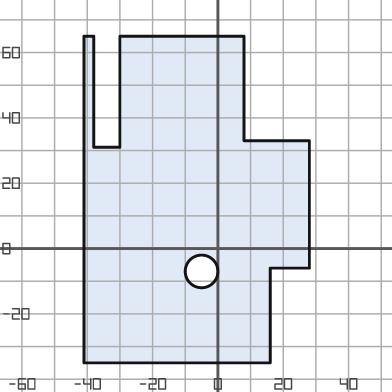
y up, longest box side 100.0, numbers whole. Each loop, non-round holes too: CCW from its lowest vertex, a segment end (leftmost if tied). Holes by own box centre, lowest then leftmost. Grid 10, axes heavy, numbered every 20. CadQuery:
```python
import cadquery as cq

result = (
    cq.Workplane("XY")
    .moveTo(-41.0, -35.0)
    .lineTo(16.0, -35.0)
    .lineTo(16.0, -6.0)
    .lineTo(28.0, -6.0)
    .lineTo(28.0, 33.0)
    .lineTo(8.0, 33.0)
    .lineTo(8.0, 65.0)
    .lineTo(-30.0, 65.0)
    .lineTo(-30.0, 31.0)
    .lineTo(-38.0, 31.0)
    .lineTo(-38.0, 65.0)
    .lineTo(-41.0, 65.0)
    .close()
    .moveTo(-5.0, -7.0)
    .circle(5.0)
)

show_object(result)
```